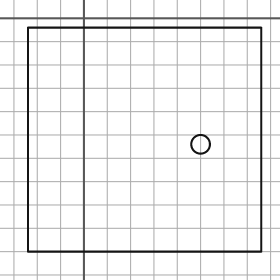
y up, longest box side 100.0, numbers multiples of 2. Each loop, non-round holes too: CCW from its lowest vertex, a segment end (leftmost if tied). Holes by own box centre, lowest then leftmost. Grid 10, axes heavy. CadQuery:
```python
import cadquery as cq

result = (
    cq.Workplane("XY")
    .moveTo(-24.0, -100.0)
    .lineTo(76.0, -100.0)
    .lineTo(76.0, -4.0)
    .lineTo(-24.0, -4.0)
    .close()
    .moveTo(50.0, -54.0)
    .circle(4.0)
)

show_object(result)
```